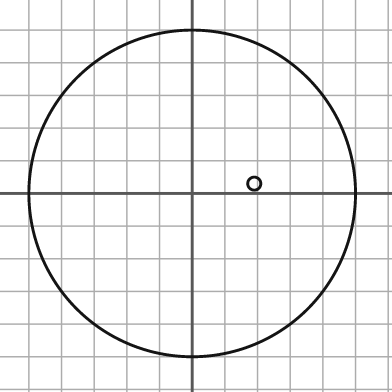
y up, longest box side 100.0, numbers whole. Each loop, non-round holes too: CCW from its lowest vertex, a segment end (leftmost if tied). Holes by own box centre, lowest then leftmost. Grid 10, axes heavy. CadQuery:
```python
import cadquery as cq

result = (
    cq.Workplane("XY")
    .moveTo(0.0, 0.0)
    .circle(50.0)
    .moveTo(19.0, 3.0)
    .circle(2.0)
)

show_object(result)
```